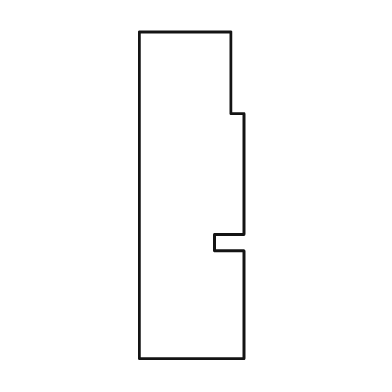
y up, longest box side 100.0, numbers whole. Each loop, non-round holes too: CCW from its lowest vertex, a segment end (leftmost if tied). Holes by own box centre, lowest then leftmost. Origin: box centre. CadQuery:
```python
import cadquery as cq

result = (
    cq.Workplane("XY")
    .moveTo(-16.0, -50.0)
    .lineTo(16.0, -50.0)
    .lineTo(16.0, -17.0)
    .lineTo(7.0, -17.0)
    .lineTo(7.0, -12.0)
    .lineTo(16.0, -12.0)
    .lineTo(16.0, 25.0)
    .lineTo(12.0, 25.0)
    .lineTo(12.0, 50.0)
    .lineTo(-16.0, 50.0)
    .close()
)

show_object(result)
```